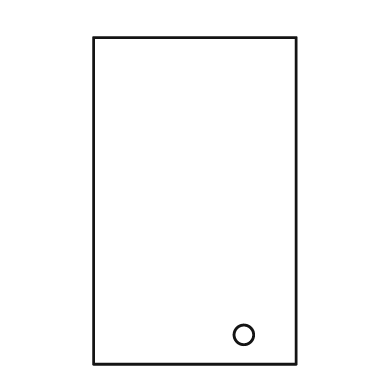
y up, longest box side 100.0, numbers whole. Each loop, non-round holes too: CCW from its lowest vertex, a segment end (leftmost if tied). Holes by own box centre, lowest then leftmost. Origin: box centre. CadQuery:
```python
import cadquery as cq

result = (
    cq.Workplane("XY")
    .moveTo(-31.0, -50.0)
    .lineTo(31.0, -50.0)
    .lineTo(31.0, 50.0)
    .lineTo(-31.0, 50.0)
    .close()
    .moveTo(15.0, -41.0)
    .circle(3.0)
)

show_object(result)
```